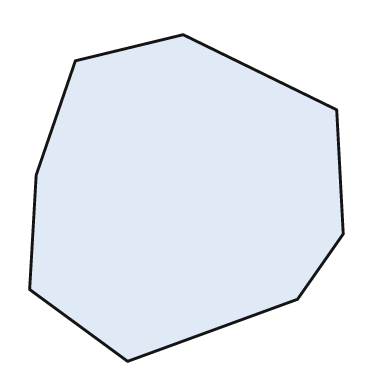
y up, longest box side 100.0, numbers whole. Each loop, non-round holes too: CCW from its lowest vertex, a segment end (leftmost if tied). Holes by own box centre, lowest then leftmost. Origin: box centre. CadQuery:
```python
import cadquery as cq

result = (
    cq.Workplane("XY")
    .moveTo(-18.0, -50.0)
    .lineTo(34.0, -31.0)
    .lineTo(48.0, -11.0)
    .lineTo(46.0, 27.0)
    .lineTo(-1.0, 50.0)
    .lineTo(-34.0, 42.0)
    .lineTo(-46.0, 7.0)
    .lineTo(-48.0, -28.0)
    .close()
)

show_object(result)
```